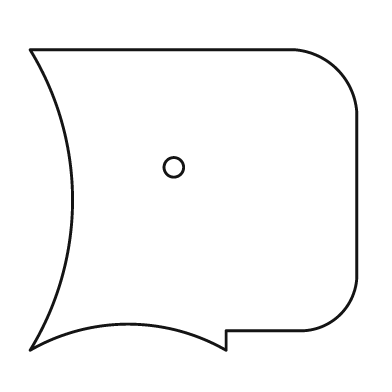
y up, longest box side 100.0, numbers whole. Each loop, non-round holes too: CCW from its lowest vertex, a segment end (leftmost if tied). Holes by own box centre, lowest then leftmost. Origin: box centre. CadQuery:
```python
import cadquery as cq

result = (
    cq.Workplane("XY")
    .moveTo(-50.0, -46.0)
    .threePointArc((-20.0, -38.0), (10.0, -46.0))
    .lineTo(10.0, -40.0)
    .lineTo(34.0, -40.0)
    .threePointArc((45.0, -35.0), (50.0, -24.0))
    .lineTo(50.0, 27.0)
    .threePointArc((44.0, 40.0), (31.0, 46.0))
    .lineTo(-50.0, 46.0)
    .threePointArc((-37.0, 0.0), (-50.0, -46.0))
    .close()
    .moveTo(-6.0, 10.0)
    .circle(3.0)
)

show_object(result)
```